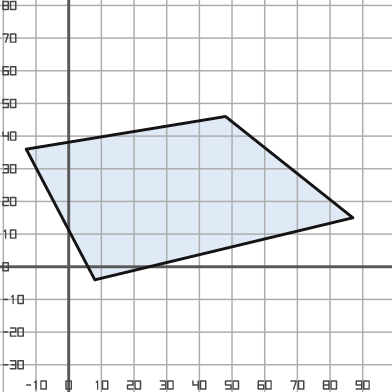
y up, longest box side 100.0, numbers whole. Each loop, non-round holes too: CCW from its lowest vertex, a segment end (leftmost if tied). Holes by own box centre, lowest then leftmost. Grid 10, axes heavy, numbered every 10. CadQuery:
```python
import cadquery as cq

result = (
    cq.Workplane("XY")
    .moveTo(8.0, -4.0)
    .lineTo(87.0, 15.0)
    .lineTo(48.0, 46.0)
    .lineTo(-13.0, 36.0)
    .close()
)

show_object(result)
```